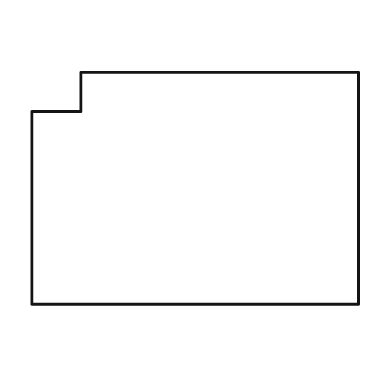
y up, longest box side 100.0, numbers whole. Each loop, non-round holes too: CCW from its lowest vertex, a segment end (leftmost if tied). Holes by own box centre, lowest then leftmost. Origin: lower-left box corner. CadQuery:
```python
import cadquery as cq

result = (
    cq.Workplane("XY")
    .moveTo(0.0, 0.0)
    .lineTo(100.0, 0.0)
    .lineTo(100.0, 71.0)
    .lineTo(15.0, 71.0)
    .lineTo(15.0, 59.0)
    .lineTo(0.0, 59.0)
    .close()
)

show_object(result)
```